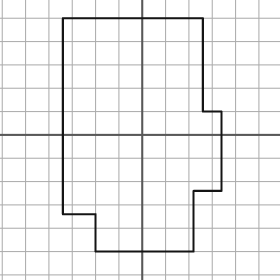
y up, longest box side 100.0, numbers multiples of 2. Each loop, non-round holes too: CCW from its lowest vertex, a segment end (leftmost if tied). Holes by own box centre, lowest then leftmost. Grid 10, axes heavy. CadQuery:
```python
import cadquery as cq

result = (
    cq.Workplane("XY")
    .moveTo(-20.0, -50.0)
    .lineTo(22.0, -50.0)
    .lineTo(22.0, -24.0)
    .lineTo(34.0, -24.0)
    .lineTo(34.0, 10.0)
    .lineTo(26.0, 10.0)
    .lineTo(26.0, 50.0)
    .lineTo(-34.0, 50.0)
    .lineTo(-34.0, -34.0)
    .lineTo(-20.0, -34.0)
    .close()
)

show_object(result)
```